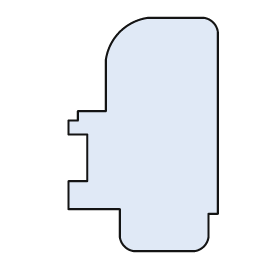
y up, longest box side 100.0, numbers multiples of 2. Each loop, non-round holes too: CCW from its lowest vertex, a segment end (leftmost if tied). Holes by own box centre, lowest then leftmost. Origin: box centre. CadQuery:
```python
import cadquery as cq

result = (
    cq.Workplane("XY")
    .moveTo(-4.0, -50.0)
    .lineTo(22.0, -50.0)
    .threePointArc((26.0, -48.0), (28.0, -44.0))
    .lineTo(28.0, -34.0)
    .lineTo(32.0, -34.0)
    .lineTo(32.0, 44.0)
    .threePointArc((30.0, 48.0), (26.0, 50.0))
    .lineTo(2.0, 50.0)
    .threePointArc((-10.0, 44.0), (-16.0, 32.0))
    .lineTo(-16.0, 10.0)
    .lineTo(-28.0, 10.0)
    .lineTo(-28.0, 6.0)
    .lineTo(-32.0, 6.0)
    .lineTo(-32.0, 0.0)
    .lineTo(-24.0, 0.0)
    .lineTo(-24.0, -20.0)
    .lineTo(-32.0, -20.0)
    .lineTo(-32.0, -32.0)
    .lineTo(-10.0, -32.0)
    .lineTo(-10.0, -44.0)
    .threePointArc((-8.0, -48.0), (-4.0, -50.0))
    .close()
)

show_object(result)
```